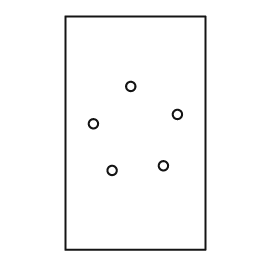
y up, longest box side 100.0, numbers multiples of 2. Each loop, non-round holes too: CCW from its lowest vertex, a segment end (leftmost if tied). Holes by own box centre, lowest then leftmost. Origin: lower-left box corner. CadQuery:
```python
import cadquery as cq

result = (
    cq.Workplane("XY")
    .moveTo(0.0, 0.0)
    .lineTo(60.0, 0.0)
    .lineTo(60.0, 100.0)
    .lineTo(0.0, 100.0)
    .close()
    .moveTo(20.0, 34.0)
    .circle(2.0)
    .moveTo(42.0, 36.0)
    .circle(2.0)
    .moveTo(12.0, 54.0)
    .circle(2.0)
    .moveTo(48.0, 58.0)
    .circle(2.0)
    .moveTo(28.0, 70.0)
    .circle(2.0)
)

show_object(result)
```